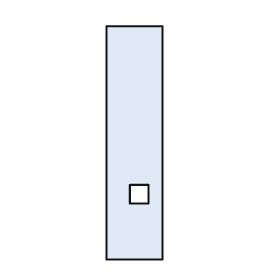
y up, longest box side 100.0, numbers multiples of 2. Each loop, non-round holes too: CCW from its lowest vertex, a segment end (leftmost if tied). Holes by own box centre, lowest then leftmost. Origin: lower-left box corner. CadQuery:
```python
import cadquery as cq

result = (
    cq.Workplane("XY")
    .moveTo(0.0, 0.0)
    .lineTo(24.0, 0.0)
    .lineTo(24.0, 100.0)
    .lineTo(0.0, 100.0)
    .close()
    .moveTo(10.0, 24.0)
    .lineTo(18.0, 24.0)
    .lineTo(18.0, 32.0)
    .lineTo(10.0, 32.0)
    .close()
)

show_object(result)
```